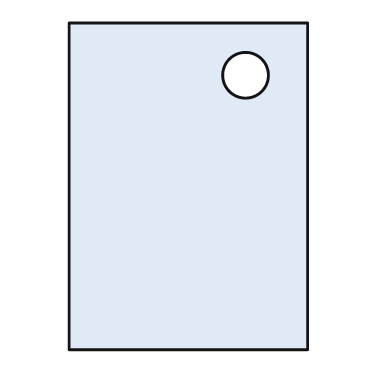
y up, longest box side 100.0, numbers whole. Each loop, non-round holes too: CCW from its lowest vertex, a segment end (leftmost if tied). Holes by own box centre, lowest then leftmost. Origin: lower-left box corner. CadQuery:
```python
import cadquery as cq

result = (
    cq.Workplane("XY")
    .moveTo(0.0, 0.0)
    .lineTo(73.0, 0.0)
    .lineTo(73.0, 100.0)
    .lineTo(0.0, 100.0)
    .close()
    .moveTo(54.0, 84.0)
    .circle(7.0)
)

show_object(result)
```